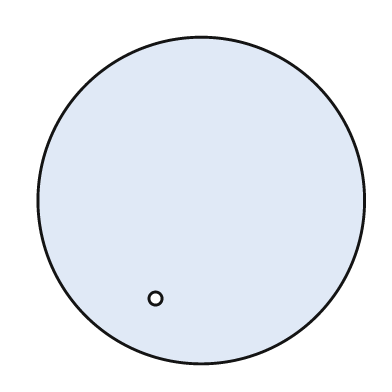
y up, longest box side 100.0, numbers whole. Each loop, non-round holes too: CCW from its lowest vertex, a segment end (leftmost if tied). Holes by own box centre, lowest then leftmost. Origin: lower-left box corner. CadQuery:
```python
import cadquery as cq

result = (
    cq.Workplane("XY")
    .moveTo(50.0, 50.0)
    .circle(50.0)
    .moveTo(36.0, 20.0)
    .circle(2.0)
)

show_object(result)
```